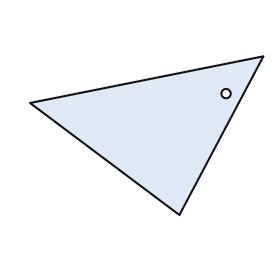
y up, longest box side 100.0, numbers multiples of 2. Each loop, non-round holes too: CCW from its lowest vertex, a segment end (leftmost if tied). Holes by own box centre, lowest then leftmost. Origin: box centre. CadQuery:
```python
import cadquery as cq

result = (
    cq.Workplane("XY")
    .moveTo(14.0, -34.0)
    .lineTo(50.0, 34.0)
    .lineTo(-50.0, 14.0)
    .close()
    .moveTo(34.0, 18.0)
    .circle(2.0)
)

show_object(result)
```